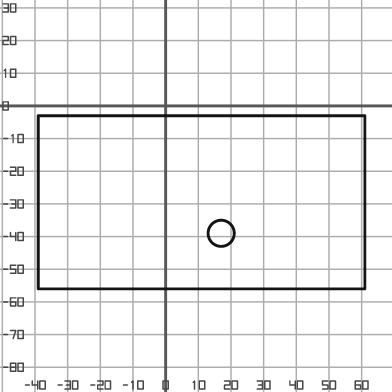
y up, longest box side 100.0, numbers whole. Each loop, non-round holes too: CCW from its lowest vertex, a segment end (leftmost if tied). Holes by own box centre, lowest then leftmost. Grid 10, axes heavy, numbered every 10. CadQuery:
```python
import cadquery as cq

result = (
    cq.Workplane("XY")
    .moveTo(-39.0, -56.0)
    .lineTo(61.0, -56.0)
    .lineTo(61.0, -3.0)
    .lineTo(-39.0, -3.0)
    .close()
    .moveTo(17.0, -39.0)
    .circle(4.0)
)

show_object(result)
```